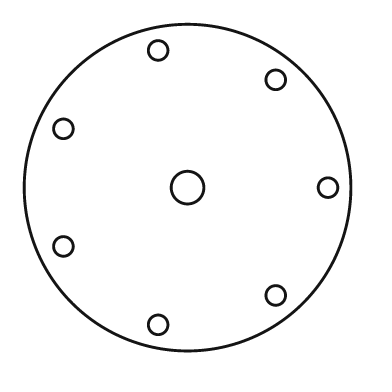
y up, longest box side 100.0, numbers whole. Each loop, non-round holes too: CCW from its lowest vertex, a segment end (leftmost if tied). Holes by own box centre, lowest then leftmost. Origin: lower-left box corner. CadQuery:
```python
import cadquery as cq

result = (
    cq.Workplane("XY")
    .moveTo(50.0, 50.0)
    .circle(50.0)
    .moveTo(41.0, 8.0)
    .circle(3.0)
    .moveTo(77.0, 17.0)
    .circle(3.0)
    .moveTo(12.0, 32.0)
    .circle(3.0)
    .moveTo(50.0, 50.0)
    .circle(5.0)
    .moveTo(93.0, 50.0)
    .circle(3.0)
    .moveTo(12.0, 68.0)
    .circle(3.0)
    .moveTo(77.0, 83.0)
    .circle(3.0)
    .moveTo(41.0, 92.0)
    .circle(3.0)
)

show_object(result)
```